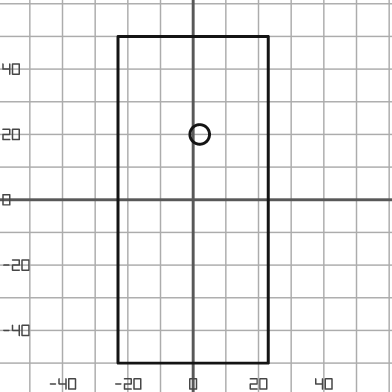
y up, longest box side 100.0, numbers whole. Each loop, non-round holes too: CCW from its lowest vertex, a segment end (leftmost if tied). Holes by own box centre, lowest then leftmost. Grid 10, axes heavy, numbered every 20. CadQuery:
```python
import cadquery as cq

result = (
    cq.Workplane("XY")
    .moveTo(-23.0, -50.0)
    .lineTo(23.0, -50.0)
    .lineTo(23.0, 50.0)
    .lineTo(-23.0, 50.0)
    .close()
    .moveTo(2.0, 20.0)
    .circle(3.0)
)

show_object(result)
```